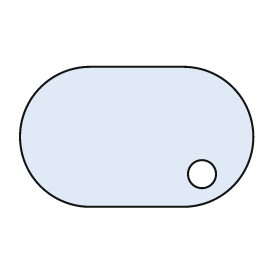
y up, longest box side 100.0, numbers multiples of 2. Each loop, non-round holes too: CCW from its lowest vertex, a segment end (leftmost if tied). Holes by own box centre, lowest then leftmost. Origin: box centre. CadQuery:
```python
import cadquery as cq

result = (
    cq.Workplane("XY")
    .moveTo(-20.0, -30.0)
    .lineTo(20.0, -30.0)
    .threePointArc((50.0, 0.0), (20.0, 30.0))
    .lineTo(-20.0, 30.0)
    .threePointArc((-50.0, 0.0), (-20.0, -30.0))
    .close()
    .moveTo(28.0, -16.0)
    .circle(6.0)
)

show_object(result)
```